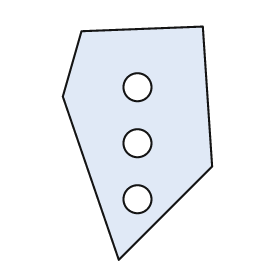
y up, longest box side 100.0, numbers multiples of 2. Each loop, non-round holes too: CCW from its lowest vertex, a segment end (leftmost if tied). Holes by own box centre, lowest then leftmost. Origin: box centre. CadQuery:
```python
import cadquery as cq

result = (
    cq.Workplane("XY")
    .moveTo(-8.0, -50.0)
    .lineTo(32.0, -10.0)
    .lineTo(28.0, 50.0)
    .lineTo(-24.0, 48.0)
    .lineTo(-32.0, 20.0)
    .close()
    .moveTo(0.0, -24.0)
    .circle(6.0)
    .moveTo(0.0, 0.0)
    .circle(6.0)
    .moveTo(0.0, 24.0)
    .circle(6.0)
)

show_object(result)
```